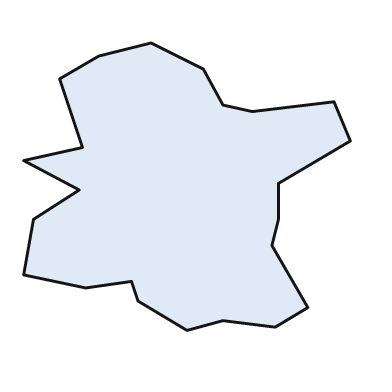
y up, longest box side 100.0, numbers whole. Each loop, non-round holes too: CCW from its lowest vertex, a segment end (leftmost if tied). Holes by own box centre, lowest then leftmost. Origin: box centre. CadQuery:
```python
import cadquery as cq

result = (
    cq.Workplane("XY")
    .moveTo(0.0, -44.0)
    .lineTo(11.0, -41.0)
    .lineTo(27.0, -43.0)
    .lineTo(37.0, -37.0)
    .lineTo(26.0, -18.0)
    .lineTo(28.0, -10.0)
    .lineTo(28.0, 1.0)
    .lineTo(50.0, 14.0)
    .lineTo(45.0, 26.0)
    .lineTo(20.0, 23.0)
    .lineTo(11.0, 25.0)
    .lineTo(5.0, 36.0)
    .lineTo(-11.0, 44.0)
    .lineTo(-27.0, 40.0)
    .lineTo(-39.0, 33.0)
    .lineTo(-32.0, 12.0)
    .lineTo(-50.0, 8.0)
    .lineTo(-33.0, -1.0)
    .lineTo(-47.0, -10.0)
    .lineTo(-50.0, -27.0)
    .lineTo(-31.0, -31.0)
    .lineTo(-17.0, -29.0)
    .lineTo(-15.0, -35.0)
    .close()
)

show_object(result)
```